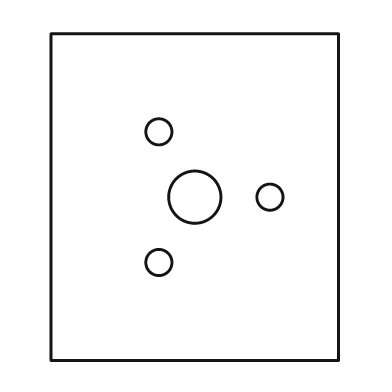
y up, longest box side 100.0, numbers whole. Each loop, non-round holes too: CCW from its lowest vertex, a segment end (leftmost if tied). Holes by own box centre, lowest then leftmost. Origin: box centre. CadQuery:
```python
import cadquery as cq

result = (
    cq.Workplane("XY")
    .moveTo(-44.0, -50.0)
    .lineTo(44.0, -50.0)
    .lineTo(44.0, 50.0)
    .lineTo(-44.0, 50.0)
    .close()
    .moveTo(-11.0, -20.0)
    .circle(4.0)
    .moveTo(0.0, 0.0)
    .circle(8.0)
    .moveTo(23.0, 0.0)
    .circle(4.0)
    .moveTo(-11.0, 20.0)
    .circle(4.0)
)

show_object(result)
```